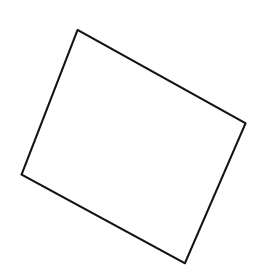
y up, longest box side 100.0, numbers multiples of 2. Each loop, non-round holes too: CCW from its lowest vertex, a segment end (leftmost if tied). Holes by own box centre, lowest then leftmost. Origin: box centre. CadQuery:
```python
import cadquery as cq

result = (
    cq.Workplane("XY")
    .moveTo(22.0, -50.0)
    .lineTo(48.0, 10.0)
    .lineTo(-24.0, 50.0)
    .lineTo(-48.0, -12.0)
    .close()
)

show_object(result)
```